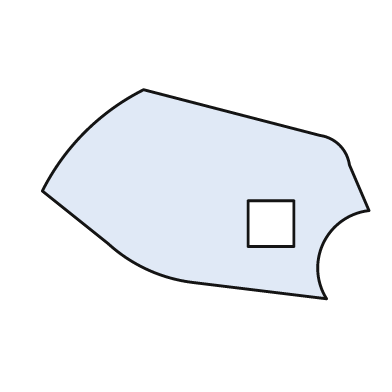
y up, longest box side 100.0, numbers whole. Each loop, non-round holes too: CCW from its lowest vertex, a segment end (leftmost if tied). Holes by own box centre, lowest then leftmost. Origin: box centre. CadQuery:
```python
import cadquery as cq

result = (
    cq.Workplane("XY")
    .moveTo(37.0, -32.0)
    .threePointArc((36.0, -15.0), (50.0, -5.0))
    .lineTo(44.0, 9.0)
    .threePointArc((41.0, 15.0), (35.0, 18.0))
    .lineTo(-19.0, 32.0)
    .threePointArc((-37.0, 19.0), (-50.0, 1.0))
    .lineTo(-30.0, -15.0)
    .threePointArc((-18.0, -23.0), (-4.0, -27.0))
    .close()
    .moveTo(13.0, -16.0)
    .lineTo(27.0, -16.0)
    .lineTo(27.0, -2.0)
    .lineTo(13.0, -2.0)
    .close()
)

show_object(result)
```